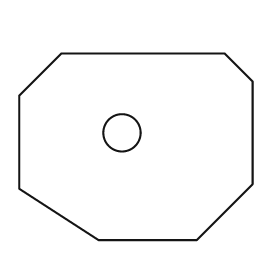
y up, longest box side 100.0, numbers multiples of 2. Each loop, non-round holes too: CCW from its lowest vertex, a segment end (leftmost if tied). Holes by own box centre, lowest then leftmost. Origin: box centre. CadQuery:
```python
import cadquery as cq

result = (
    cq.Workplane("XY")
    .moveTo(-16.0, -40.0)
    .lineTo(26.0, -40.0)
    .lineTo(50.0, -16.0)
    .lineTo(50.0, 28.0)
    .lineTo(38.0, 40.0)
    .lineTo(-32.0, 40.0)
    .lineTo(-50.0, 22.0)
    .lineTo(-50.0, -18.0)
    .close()
    .moveTo(-6.0, 6.0)
    .circle(8.0)
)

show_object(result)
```